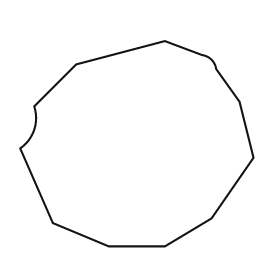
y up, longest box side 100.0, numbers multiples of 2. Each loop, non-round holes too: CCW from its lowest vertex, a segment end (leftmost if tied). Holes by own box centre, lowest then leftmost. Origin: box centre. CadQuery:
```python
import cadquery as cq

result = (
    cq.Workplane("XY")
    .moveTo(-12.0, -44.0)
    .lineTo(12.0, -44.0)
    .lineTo(32.0, -32.0)
    .lineTo(50.0, -6.0)
    .lineTo(44.0, 18.0)
    .lineTo(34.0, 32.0)
    .threePointArc((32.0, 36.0), (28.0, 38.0))
    .lineTo(12.0, 44.0)
    .lineTo(-26.0, 34.0)
    .lineTo(-44.0, 16.0)
    .threePointArc((-44.0, 6.0), (-50.0, -2.0))
    .lineTo(-36.0, -34.0)
    .close()
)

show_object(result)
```